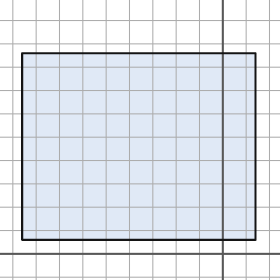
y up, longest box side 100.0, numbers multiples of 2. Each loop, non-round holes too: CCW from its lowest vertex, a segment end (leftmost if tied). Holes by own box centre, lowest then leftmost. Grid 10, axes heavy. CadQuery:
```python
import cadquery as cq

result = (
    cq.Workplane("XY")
    .moveTo(-86.0, 6.0)
    .lineTo(14.0, 6.0)
    .lineTo(14.0, 86.0)
    .lineTo(-86.0, 86.0)
    .close()
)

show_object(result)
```